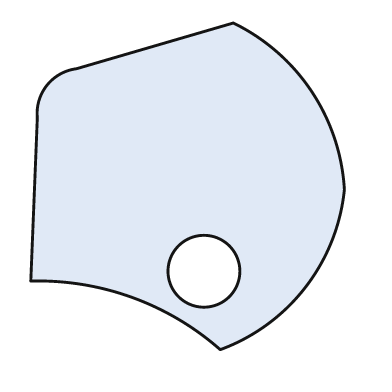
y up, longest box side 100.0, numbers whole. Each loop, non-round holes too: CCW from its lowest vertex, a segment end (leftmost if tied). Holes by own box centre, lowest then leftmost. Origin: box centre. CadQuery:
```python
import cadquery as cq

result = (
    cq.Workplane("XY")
    .moveTo(10.0, -50.0)
    .threePointArc((36.0, -31.0), (48.0, -1.0))
    .threePointArc((38.0, 29.0), (14.0, 50.0))
    .lineTo(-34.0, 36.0)
    .threePointArc((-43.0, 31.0), (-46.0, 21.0))
    .lineTo(-48.0, -29.0)
    .threePointArc((-17.0, -34.0), (10.0, -50.0))
    .close()
    .moveTo(5.0, -26.0)
    .circle(11.0)
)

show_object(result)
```